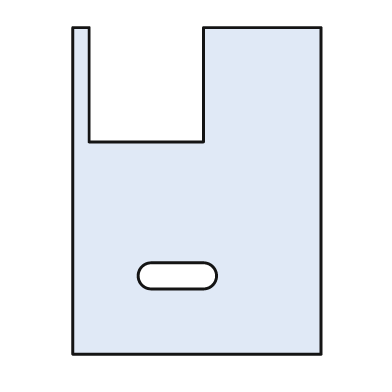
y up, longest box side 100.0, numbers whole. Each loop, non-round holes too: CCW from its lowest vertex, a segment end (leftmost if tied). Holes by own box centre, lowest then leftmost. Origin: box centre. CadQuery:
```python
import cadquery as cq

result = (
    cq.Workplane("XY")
    .moveTo(-38.0, -50.0)
    .lineTo(38.0, -50.0)
    .lineTo(38.0, 50.0)
    .lineTo(2.0, 50.0)
    .lineTo(2.0, 15.0)
    .lineTo(-33.0, 15.0)
    .lineTo(-33.0, 50.0)
    .lineTo(-38.0, 50.0)
    .close()
    .moveTo(-14.0, -30.0)
    .lineTo(2.0, -30.0)
    .threePointArc((6.0, -26.0), (2.0, -22.0))
    .lineTo(-14.0, -22.0)
    .threePointArc((-18.0, -26.0), (-14.0, -30.0))
    .close()
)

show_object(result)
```